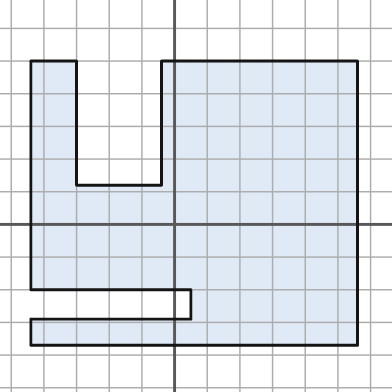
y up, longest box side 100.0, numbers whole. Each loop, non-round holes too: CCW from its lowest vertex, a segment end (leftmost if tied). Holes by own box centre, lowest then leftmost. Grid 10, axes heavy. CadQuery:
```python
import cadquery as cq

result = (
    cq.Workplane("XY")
    .moveTo(-44.0, -37.0)
    .lineTo(56.0, -37.0)
    .lineTo(56.0, 50.0)
    .lineTo(-4.0, 50.0)
    .lineTo(-4.0, 12.0)
    .lineTo(-30.0, 12.0)
    .lineTo(-30.0, 50.0)
    .lineTo(-44.0, 50.0)
    .lineTo(-44.0, -20.0)
    .lineTo(5.0, -20.0)
    .lineTo(5.0, -29.0)
    .lineTo(-44.0, -29.0)
    .close()
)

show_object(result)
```